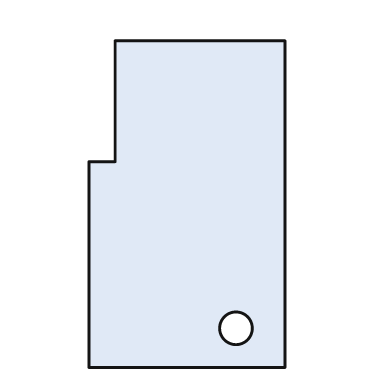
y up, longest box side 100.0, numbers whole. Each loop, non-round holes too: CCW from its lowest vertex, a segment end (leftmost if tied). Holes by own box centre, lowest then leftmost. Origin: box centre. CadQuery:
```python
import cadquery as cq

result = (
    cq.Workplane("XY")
    .moveTo(-30.0, -50.0)
    .lineTo(30.0, -50.0)
    .lineTo(30.0, 50.0)
    .lineTo(-22.0, 50.0)
    .lineTo(-22.0, 13.0)
    .lineTo(-30.0, 13.0)
    .close()
    .moveTo(15.0, -38.0)
    .circle(5.0)
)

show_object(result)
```